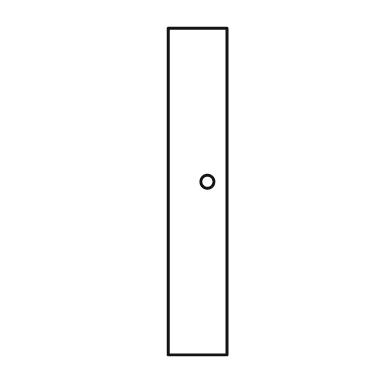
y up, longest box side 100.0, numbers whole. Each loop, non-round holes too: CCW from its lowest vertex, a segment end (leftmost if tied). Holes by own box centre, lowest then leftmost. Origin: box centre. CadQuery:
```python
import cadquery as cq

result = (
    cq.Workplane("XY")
    .moveTo(-9.0, -50.0)
    .lineTo(9.0, -50.0)
    .lineTo(9.0, 50.0)
    .lineTo(-9.0, 50.0)
    .close()
    .moveTo(3.0, 3.0)
    .circle(2.0)
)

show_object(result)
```